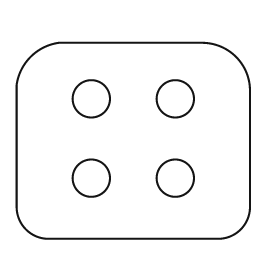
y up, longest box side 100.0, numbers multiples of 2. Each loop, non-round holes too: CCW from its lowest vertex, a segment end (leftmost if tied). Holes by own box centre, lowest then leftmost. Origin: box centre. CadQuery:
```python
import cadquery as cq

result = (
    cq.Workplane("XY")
    .moveTo(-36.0, -42.0)
    .lineTo(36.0, -42.0)
    .threePointArc((46.0, -38.0), (50.0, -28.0))
    .lineTo(50.0, 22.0)
    .threePointArc((44.0, 36.0), (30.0, 42.0))
    .lineTo(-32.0, 42.0)
    .threePointArc((-44.0, 36.0), (-50.0, 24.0))
    .lineTo(-50.0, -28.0)
    .threePointArc((-46.0, -38.0), (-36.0, -42.0))
    .close()
    .moveTo(-18.0, -16.0)
    .circle(8.0)
    .moveTo(18.0, -16.0)
    .circle(8.0)
    .moveTo(-18.0, 18.0)
    .circle(8.0)
    .moveTo(18.0, 18.0)
    .circle(8.0)
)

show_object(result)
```